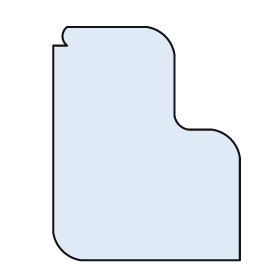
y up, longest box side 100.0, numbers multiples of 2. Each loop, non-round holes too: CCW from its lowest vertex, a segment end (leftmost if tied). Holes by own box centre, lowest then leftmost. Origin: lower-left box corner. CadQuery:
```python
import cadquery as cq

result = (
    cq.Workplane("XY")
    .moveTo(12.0, 0.0)
    .lineTo(80.0, 0.0)
    .lineTo(80.0, 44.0)
    .threePointArc((76.0, 52.0), (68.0, 56.0))
    .lineTo(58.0, 56.0)
    .threePointArc((54.0, 58.0), (52.0, 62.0))
    .lineTo(52.0, 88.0)
    .threePointArc((48.0, 96.0), (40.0, 100.0))
    .lineTo(6.0, 100.0)
    .threePointArc((4.0, 96.0), (6.0, 92.0))
    .lineTo(0.0, 92.0)
    .lineTo(0.0, 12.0)
    .threePointArc((4.0, 4.0), (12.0, 0.0))
    .close()
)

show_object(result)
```